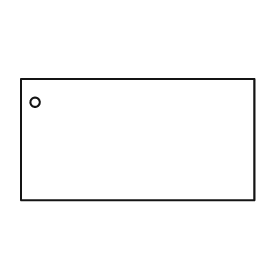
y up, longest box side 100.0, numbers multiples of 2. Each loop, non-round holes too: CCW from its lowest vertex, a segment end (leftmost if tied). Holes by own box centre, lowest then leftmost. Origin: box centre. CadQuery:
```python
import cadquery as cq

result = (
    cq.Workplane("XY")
    .moveTo(-50.0, -26.0)
    .lineTo(50.0, -26.0)
    .lineTo(50.0, 26.0)
    .lineTo(-50.0, 26.0)
    .close()
    .moveTo(-44.0, 16.0)
    .circle(2.0)
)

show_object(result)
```